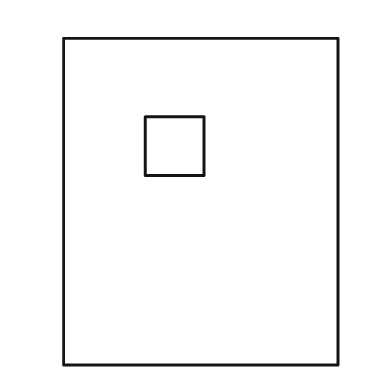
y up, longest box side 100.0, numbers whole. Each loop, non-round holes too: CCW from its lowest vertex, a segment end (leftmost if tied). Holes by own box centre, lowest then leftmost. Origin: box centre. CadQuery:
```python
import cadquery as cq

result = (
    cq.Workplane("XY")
    .moveTo(-42.0, -50.0)
    .lineTo(42.0, -50.0)
    .lineTo(42.0, 50.0)
    .lineTo(-42.0, 50.0)
    .close()
    .moveTo(-17.0, 8.0)
    .lineTo(1.0, 8.0)
    .lineTo(1.0, 26.0)
    .lineTo(-17.0, 26.0)
    .close()
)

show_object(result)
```